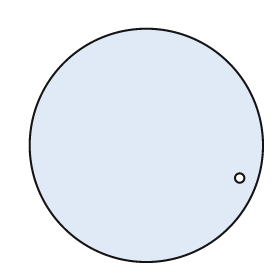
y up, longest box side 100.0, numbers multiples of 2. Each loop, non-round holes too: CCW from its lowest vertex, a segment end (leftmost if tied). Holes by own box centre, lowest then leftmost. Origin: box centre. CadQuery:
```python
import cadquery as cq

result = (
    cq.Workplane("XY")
    .moveTo(0.0, 0.0)
    .circle(50.0)
    .moveTo(40.0, -14.0)
    .circle(2.0)
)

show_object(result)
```